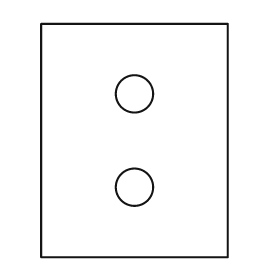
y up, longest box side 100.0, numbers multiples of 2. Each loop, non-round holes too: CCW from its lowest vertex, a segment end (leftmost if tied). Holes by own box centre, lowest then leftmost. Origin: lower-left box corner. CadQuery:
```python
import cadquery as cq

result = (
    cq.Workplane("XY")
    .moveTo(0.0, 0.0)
    .lineTo(80.0, 0.0)
    .lineTo(80.0, 100.0)
    .lineTo(0.0, 100.0)
    .close()
    .moveTo(40.0, 30.0)
    .circle(8.0)
    .moveTo(40.0, 70.0)
    .circle(8.0)
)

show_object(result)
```